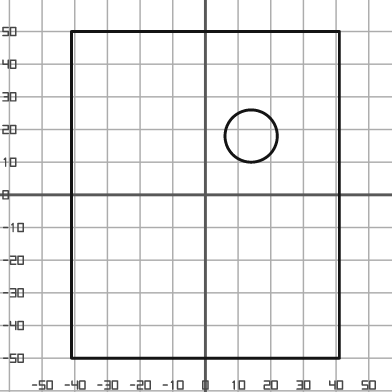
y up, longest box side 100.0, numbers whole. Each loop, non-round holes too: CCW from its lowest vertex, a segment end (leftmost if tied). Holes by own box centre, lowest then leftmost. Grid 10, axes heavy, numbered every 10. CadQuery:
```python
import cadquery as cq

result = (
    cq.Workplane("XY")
    .moveTo(-41.0, -50.0)
    .lineTo(41.0, -50.0)
    .lineTo(41.0, 50.0)
    .lineTo(-41.0, 50.0)
    .close()
    .moveTo(14.0, 18.0)
    .circle(8.0)
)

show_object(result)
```